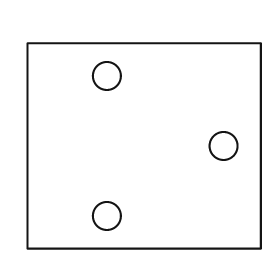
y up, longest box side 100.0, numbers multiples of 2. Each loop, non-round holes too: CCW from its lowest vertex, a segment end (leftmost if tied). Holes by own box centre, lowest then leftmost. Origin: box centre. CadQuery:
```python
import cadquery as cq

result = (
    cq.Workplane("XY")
    .moveTo(-50.0, -44.0)
    .lineTo(50.0, -44.0)
    .lineTo(50.0, 44.0)
    .lineTo(-50.0, 44.0)
    .close()
    .moveTo(-16.0, -30.0)
    .circle(6.0)
    .moveTo(34.0, 0.0)
    .circle(6.0)
    .moveTo(-16.0, 30.0)
    .circle(6.0)
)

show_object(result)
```